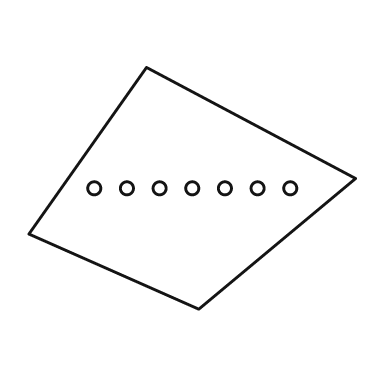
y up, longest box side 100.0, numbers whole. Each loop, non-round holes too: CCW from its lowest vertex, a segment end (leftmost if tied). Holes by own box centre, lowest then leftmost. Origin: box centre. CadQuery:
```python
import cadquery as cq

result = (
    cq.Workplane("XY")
    .moveTo(2.0, -37.0)
    .lineTo(50.0, 3.0)
    .lineTo(-14.0, 37.0)
    .lineTo(-50.0, -14.0)
    .close()
    .moveTo(-30.0, 0.0)
    .circle(2.0)
    .moveTo(-20.0, 0.0)
    .circle(2.0)
    .moveTo(-10.0, 0.0)
    .circle(2.0)
    .moveTo(0.0, 0.0)
    .circle(2.0)
    .moveTo(10.0, 0.0)
    .circle(2.0)
    .moveTo(20.0, 0.0)
    .circle(2.0)
    .moveTo(30.0, 0.0)
    .circle(2.0)
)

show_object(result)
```